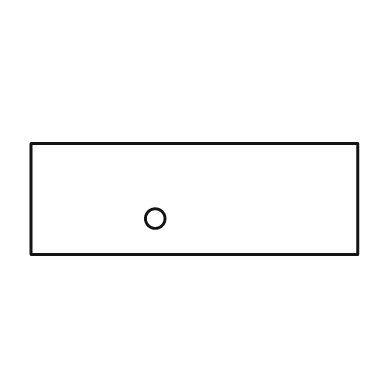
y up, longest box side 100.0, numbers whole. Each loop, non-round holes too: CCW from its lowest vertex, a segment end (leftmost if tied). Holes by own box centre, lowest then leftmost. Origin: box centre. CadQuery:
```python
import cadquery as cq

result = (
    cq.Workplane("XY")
    .moveTo(-50.0, -17.0)
    .lineTo(50.0, -17.0)
    .lineTo(50.0, 17.0)
    .lineTo(-50.0, 17.0)
    .close()
    .moveTo(-12.0, -6.0)
    .circle(3.0)
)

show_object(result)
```